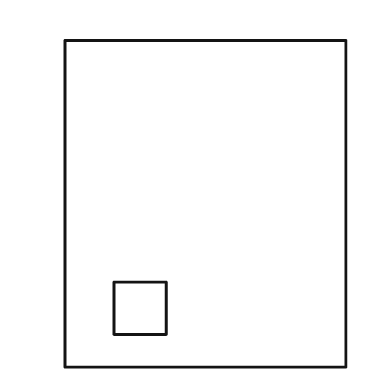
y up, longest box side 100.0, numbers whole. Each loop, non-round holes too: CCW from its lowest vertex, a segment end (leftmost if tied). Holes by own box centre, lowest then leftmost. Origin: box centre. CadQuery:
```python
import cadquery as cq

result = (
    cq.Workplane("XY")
    .moveTo(-43.0, -50.0)
    .lineTo(43.0, -50.0)
    .lineTo(43.0, 50.0)
    .lineTo(-43.0, 50.0)
    .close()
    .moveTo(-28.0, -40.0)
    .lineTo(-12.0, -40.0)
    .lineTo(-12.0, -24.0)
    .lineTo(-28.0, -24.0)
    .close()
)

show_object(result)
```